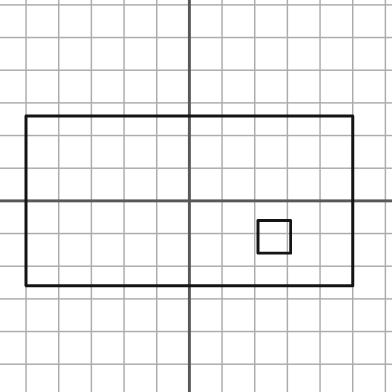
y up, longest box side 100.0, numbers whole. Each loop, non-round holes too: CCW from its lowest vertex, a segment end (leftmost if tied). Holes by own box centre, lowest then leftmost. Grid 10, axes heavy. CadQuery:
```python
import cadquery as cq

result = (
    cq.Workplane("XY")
    .moveTo(-50.0, -26.0)
    .lineTo(50.0, -26.0)
    .lineTo(50.0, 26.0)
    .lineTo(-50.0, 26.0)
    .close()
    .moveTo(21.0, -16.0)
    .lineTo(31.0, -16.0)
    .lineTo(31.0, -6.0)
    .lineTo(21.0, -6.0)
    .close()
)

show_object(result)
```